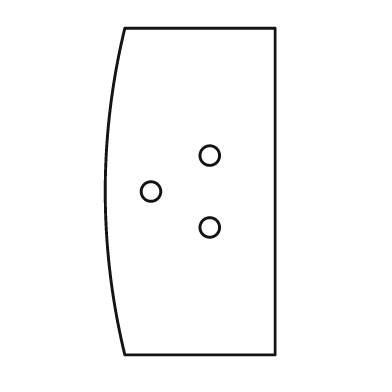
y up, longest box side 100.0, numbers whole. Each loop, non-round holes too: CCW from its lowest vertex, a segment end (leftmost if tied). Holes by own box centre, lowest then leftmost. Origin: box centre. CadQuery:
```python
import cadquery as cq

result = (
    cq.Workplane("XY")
    .moveTo(-20.0, -50.0)
    .lineTo(26.0, -50.0)
    .lineTo(26.0, 50.0)
    .lineTo(-20.0, 50.0)
    .threePointArc((-26.0, 0.0), (-20.0, -50.0))
    .close()
    .moveTo(6.0, -11.0)
    .circle(3.0)
    .moveTo(-12.0, 0.0)
    .circle(3.0)
    .moveTo(6.0, 11.0)
    .circle(3.0)
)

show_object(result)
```